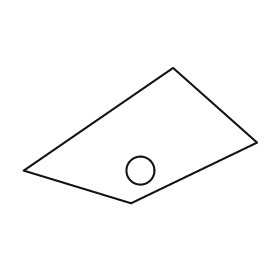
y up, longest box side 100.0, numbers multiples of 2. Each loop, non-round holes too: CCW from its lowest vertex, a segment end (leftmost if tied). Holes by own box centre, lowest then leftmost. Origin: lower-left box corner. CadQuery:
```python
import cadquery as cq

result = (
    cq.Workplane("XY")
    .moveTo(46.0, 0.0)
    .lineTo(100.0, 26.0)
    .lineTo(64.0, 58.0)
    .lineTo(0.0, 14.0)
    .close()
    .moveTo(50.0, 14.0)
    .circle(6.0)
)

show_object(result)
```